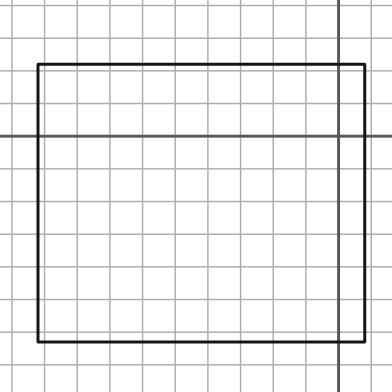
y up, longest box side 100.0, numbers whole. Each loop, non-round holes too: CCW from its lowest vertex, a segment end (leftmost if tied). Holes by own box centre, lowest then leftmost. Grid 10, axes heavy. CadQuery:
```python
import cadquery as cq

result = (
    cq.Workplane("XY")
    .moveTo(-92.0, -63.0)
    .lineTo(8.0, -63.0)
    .lineTo(8.0, 22.0)
    .lineTo(-92.0, 22.0)
    .close()
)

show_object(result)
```